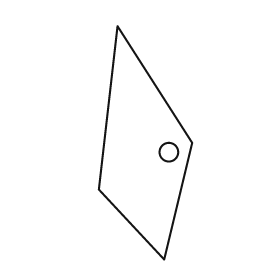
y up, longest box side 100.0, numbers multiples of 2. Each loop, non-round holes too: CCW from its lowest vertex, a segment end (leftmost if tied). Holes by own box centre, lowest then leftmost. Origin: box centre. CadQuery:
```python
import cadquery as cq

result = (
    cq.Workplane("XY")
    .moveTo(8.0, -50.0)
    .lineTo(20.0, 0.0)
    .lineTo(-12.0, 50.0)
    .lineTo(-20.0, -20.0)
    .close()
    .moveTo(10.0, -4.0)
    .circle(4.0)
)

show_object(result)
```